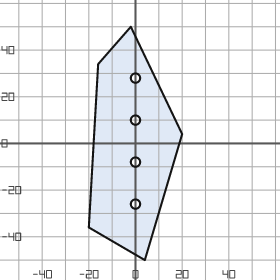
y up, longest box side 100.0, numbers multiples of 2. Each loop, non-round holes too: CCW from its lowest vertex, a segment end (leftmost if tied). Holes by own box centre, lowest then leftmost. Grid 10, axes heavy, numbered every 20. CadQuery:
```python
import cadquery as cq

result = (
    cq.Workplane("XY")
    .moveTo(4.0, -50.0)
    .lineTo(20.0, 4.0)
    .lineTo(-2.0, 50.0)
    .lineTo(-16.0, 34.0)
    .lineTo(-20.0, -36.0)
    .close()
    .moveTo(0.0, -26.0)
    .circle(2.0)
    .moveTo(0.0, -8.0)
    .circle(2.0)
    .moveTo(0.0, 10.0)
    .circle(2.0)
    .moveTo(0.0, 28.0)
    .circle(2.0)
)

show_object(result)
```